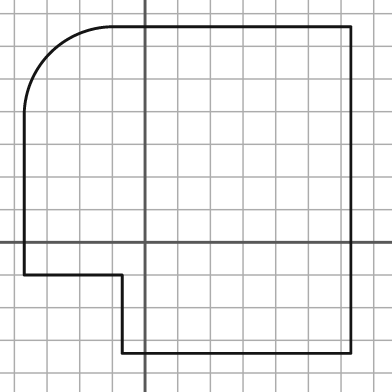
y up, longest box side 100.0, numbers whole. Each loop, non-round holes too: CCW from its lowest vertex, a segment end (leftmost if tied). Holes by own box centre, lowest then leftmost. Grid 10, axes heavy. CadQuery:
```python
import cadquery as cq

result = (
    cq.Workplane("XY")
    .moveTo(-7.0, -34.0)
    .lineTo(63.0, -34.0)
    .lineTo(63.0, 66.0)
    .lineTo(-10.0, 66.0)
    .threePointArc((-29.0, 58.0), (-37.0, 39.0))
    .lineTo(-37.0, -10.0)
    .lineTo(-7.0, -10.0)
    .close()
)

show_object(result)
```